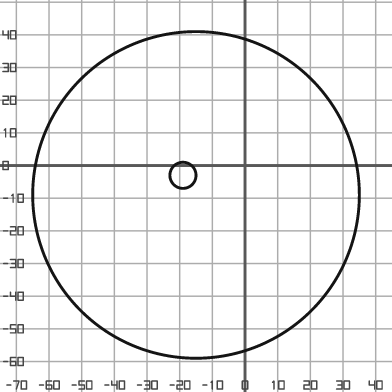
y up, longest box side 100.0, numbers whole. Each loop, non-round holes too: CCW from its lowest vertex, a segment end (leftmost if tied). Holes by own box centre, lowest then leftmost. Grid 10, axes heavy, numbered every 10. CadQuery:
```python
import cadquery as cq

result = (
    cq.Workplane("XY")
    .moveTo(-15.0, -9.0)
    .circle(50.0)
    .moveTo(-19.0, -3.0)
    .circle(4.0)
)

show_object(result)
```